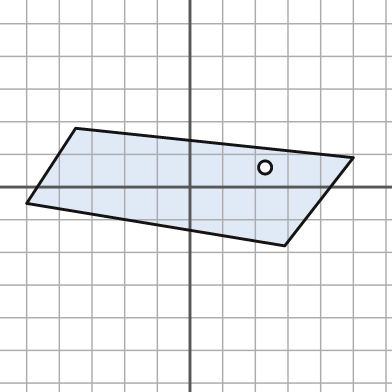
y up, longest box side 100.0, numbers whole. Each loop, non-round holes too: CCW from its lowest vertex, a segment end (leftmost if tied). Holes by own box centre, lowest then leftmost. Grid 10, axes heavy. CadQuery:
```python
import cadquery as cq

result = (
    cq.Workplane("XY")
    .moveTo(29.0, -18.0)
    .lineTo(50.0, 9.0)
    .lineTo(-35.0, 18.0)
    .lineTo(-50.0, -5.0)
    .close()
    .moveTo(23.0, 6.0)
    .circle(2.0)
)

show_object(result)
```